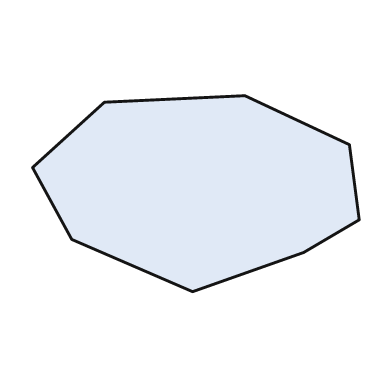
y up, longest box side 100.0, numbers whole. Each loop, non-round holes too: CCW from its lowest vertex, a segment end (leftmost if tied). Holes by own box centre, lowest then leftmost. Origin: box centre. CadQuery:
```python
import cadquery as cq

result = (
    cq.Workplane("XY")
    .moveTo(-1.0, -30.0)
    .lineTo(33.0, -18.0)
    .lineTo(50.0, -8.0)
    .lineTo(47.0, 15.0)
    .lineTo(15.0, 30.0)
    .lineTo(-28.0, 28.0)
    .lineTo(-50.0, 8.0)
    .lineTo(-38.0, -14.0)
    .close()
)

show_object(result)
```